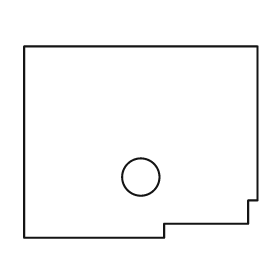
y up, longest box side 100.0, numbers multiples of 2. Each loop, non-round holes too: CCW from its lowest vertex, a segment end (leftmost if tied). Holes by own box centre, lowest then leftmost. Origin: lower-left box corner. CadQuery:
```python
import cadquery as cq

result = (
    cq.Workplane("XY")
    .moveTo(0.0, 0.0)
    .lineTo(60.0, 0.0)
    .lineTo(60.0, 6.0)
    .lineTo(96.0, 6.0)
    .lineTo(96.0, 16.0)
    .lineTo(100.0, 16.0)
    .lineTo(100.0, 82.0)
    .lineTo(0.0, 82.0)
    .close()
    .moveTo(50.0, 26.0)
    .circle(8.0)
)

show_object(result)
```